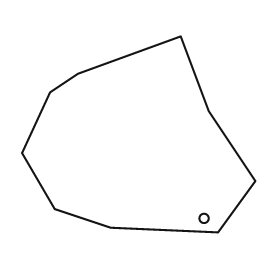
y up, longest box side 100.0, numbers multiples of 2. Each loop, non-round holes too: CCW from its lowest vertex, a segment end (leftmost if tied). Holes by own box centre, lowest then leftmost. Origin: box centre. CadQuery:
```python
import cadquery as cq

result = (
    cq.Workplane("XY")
    .moveTo(34.0, -42.0)
    .lineTo(50.0, -20.0)
    .lineTo(30.0, 10.0)
    .lineTo(18.0, 42.0)
    .lineTo(-26.0, 26.0)
    .lineTo(-38.0, 18.0)
    .lineTo(-50.0, -8.0)
    .lineTo(-36.0, -32.0)
    .lineTo(-12.0, -40.0)
    .close()
    .moveTo(28.0, -36.0)
    .circle(2.0)
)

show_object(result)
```